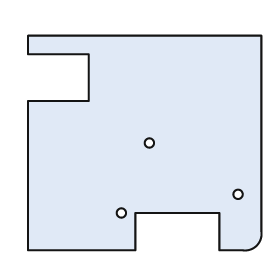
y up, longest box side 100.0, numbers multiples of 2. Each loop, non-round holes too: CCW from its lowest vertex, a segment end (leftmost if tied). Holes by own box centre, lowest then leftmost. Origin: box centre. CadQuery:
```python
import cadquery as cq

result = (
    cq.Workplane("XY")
    .moveTo(-50.0, -46.0)
    .lineTo(-4.0, -46.0)
    .lineTo(-4.0, -30.0)
    .lineTo(32.0, -30.0)
    .lineTo(32.0, -46.0)
    .lineTo(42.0, -46.0)
    .threePointArc((48.0, -44.0), (50.0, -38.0))
    .lineTo(50.0, 46.0)
    .lineTo(-50.0, 46.0)
    .lineTo(-50.0, 38.0)
    .lineTo(-24.0, 38.0)
    .lineTo(-24.0, 18.0)
    .lineTo(-50.0, 18.0)
    .close()
    .moveTo(-10.0, -30.0)
    .circle(2.0)
    .moveTo(40.0, -22.0)
    .circle(2.0)
    .moveTo(2.0, 0.0)
    .circle(2.0)
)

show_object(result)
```